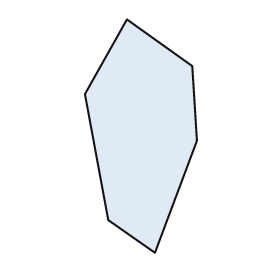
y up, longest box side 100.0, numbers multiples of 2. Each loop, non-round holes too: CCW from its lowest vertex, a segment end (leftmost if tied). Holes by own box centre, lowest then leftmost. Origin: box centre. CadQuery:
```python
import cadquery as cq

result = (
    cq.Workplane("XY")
    .moveTo(6.0, -50.0)
    .lineTo(24.0, -2.0)
    .lineTo(22.0, 30.0)
    .lineTo(-6.0, 50.0)
    .lineTo(-24.0, 18.0)
    .lineTo(-14.0, -36.0)
    .close()
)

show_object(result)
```